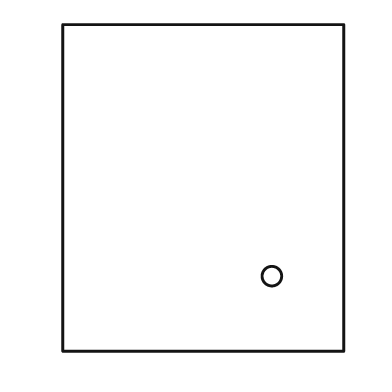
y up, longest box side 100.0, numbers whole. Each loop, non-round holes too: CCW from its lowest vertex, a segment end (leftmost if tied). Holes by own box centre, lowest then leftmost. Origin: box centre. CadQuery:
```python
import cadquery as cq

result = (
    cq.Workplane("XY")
    .moveTo(-43.0, -50.0)
    .lineTo(43.0, -50.0)
    .lineTo(43.0, 50.0)
    .lineTo(-43.0, 50.0)
    .close()
    .moveTo(21.0, -27.0)
    .circle(3.0)
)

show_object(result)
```